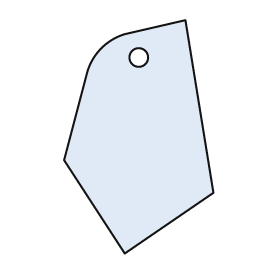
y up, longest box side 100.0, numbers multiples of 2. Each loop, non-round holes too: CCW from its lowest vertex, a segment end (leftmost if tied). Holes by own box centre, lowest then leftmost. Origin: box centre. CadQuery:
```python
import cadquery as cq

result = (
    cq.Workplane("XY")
    .moveTo(-6.0, -50.0)
    .lineTo(32.0, -24.0)
    .lineTo(20.0, 50.0)
    .lineTo(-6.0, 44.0)
    .threePointArc((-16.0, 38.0), (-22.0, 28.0))
    .lineTo(-32.0, -10.0)
    .close()
    .moveTo(0.0, 34.0)
    .circle(4.0)
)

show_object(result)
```